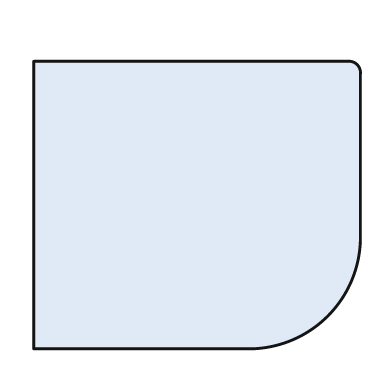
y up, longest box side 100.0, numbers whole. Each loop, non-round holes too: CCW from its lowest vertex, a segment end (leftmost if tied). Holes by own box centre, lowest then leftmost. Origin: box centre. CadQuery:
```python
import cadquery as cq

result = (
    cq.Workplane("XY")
    .moveTo(-50.0, -44.0)
    .lineTo(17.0, -44.0)
    .threePointArc((40.0, -34.0), (50.0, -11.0))
    .lineTo(50.0, 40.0)
    .threePointArc((49.0, 43.0), (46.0, 44.0))
    .lineTo(-50.0, 44.0)
    .close()
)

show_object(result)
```